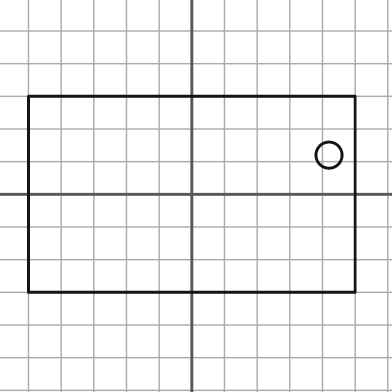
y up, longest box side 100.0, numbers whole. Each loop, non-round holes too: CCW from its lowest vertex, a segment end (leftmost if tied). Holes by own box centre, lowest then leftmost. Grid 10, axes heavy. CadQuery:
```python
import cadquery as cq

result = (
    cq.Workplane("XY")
    .moveTo(-50.0, -30.0)
    .lineTo(50.0, -30.0)
    .lineTo(50.0, 30.0)
    .lineTo(-50.0, 30.0)
    .close()
    .moveTo(42.0, 12.0)
    .circle(4.0)
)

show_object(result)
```